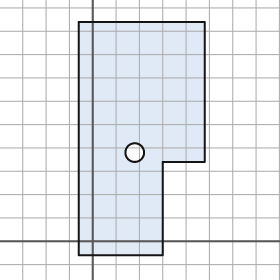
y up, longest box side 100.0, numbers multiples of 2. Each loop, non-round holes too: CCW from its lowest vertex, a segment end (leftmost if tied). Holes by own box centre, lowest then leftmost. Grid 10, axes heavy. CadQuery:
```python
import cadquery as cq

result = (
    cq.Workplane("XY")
    .moveTo(-6.0, -6.0)
    .lineTo(30.0, -6.0)
    .lineTo(30.0, 34.0)
    .lineTo(48.0, 34.0)
    .lineTo(48.0, 94.0)
    .lineTo(-6.0, 94.0)
    .close()
    .moveTo(18.0, 38.0)
    .circle(4.0)
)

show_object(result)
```